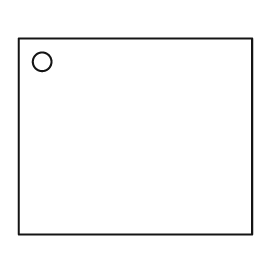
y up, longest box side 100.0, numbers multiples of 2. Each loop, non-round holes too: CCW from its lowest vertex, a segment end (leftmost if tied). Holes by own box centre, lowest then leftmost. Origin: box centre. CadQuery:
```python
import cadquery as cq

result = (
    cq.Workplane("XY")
    .moveTo(-50.0, -42.0)
    .lineTo(50.0, -42.0)
    .lineTo(50.0, 42.0)
    .lineTo(-50.0, 42.0)
    .close()
    .moveTo(-40.0, 32.0)
    .circle(4.0)
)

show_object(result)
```